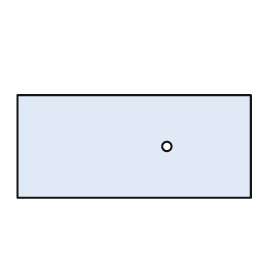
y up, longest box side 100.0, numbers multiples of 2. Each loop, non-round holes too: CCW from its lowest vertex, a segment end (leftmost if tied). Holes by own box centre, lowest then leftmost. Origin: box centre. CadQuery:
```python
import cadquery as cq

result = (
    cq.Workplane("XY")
    .moveTo(-50.0, -22.0)
    .lineTo(50.0, -22.0)
    .lineTo(50.0, 22.0)
    .lineTo(-50.0, 22.0)
    .close()
    .moveTo(14.0, 0.0)
    .circle(2.0)
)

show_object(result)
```